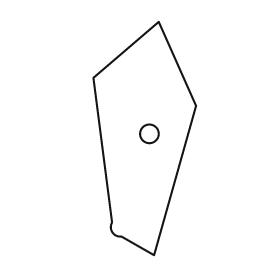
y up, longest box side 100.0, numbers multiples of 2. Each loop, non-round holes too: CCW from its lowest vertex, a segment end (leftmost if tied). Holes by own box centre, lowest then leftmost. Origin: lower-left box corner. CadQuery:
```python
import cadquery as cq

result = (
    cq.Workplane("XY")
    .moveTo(26.0, 0.0)
    .lineTo(44.0, 64.0)
    .lineTo(28.0, 100.0)
    .lineTo(0.0, 76.0)
    .lineTo(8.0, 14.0)
    .threePointArc((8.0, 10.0), (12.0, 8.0))
    .close()
    .moveTo(24.0, 52.0)
    .circle(4.0)
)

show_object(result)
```